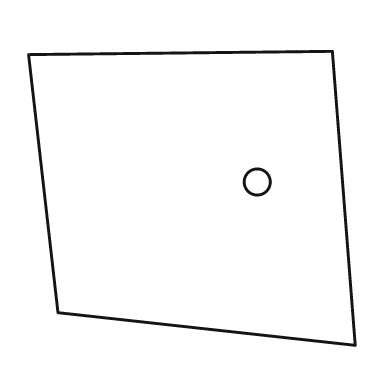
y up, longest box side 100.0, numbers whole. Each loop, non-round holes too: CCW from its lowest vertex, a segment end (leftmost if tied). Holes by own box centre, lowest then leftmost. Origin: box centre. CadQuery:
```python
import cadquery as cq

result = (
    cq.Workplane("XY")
    .moveTo(50.0, -45.0)
    .lineTo(43.0, 45.0)
    .lineTo(-50.0, 44.0)
    .lineTo(-41.0, -35.0)
    .close()
    .moveTo(20.0, 5.0)
    .circle(4.0)
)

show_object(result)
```